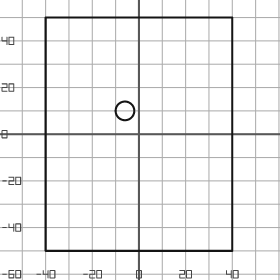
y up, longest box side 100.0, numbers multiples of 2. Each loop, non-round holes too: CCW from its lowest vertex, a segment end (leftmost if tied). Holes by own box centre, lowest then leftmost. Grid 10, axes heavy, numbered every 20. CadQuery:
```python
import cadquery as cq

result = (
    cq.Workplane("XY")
    .moveTo(-40.0, -50.0)
    .lineTo(40.0, -50.0)
    .lineTo(40.0, 50.0)
    .lineTo(-40.0, 50.0)
    .close()
    .moveTo(-6.0, 10.0)
    .circle(4.0)
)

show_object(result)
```